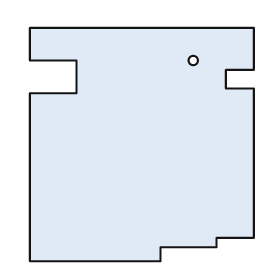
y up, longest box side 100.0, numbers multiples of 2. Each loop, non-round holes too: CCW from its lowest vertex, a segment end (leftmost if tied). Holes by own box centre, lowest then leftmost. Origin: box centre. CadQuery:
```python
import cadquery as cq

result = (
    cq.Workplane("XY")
    .moveTo(-48.0, -50.0)
    .lineTo(8.0, -50.0)
    .lineTo(8.0, -44.0)
    .lineTo(32.0, -44.0)
    .lineTo(32.0, -40.0)
    .lineTo(48.0, -40.0)
    .lineTo(48.0, 24.0)
    .lineTo(36.0, 24.0)
    .lineTo(36.0, 32.0)
    .lineTo(48.0, 32.0)
    .lineTo(48.0, 50.0)
    .lineTo(-48.0, 50.0)
    .lineTo(-48.0, 36.0)
    .lineTo(-28.0, 36.0)
    .lineTo(-28.0, 22.0)
    .lineTo(-48.0, 22.0)
    .close()
    .moveTo(22.0, 36.0)
    .circle(2.0)
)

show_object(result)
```